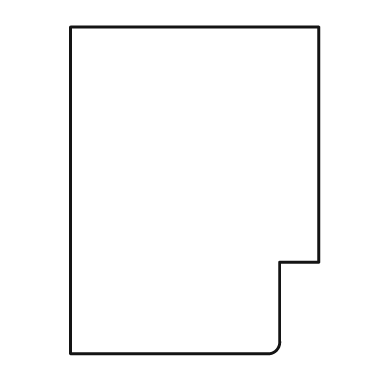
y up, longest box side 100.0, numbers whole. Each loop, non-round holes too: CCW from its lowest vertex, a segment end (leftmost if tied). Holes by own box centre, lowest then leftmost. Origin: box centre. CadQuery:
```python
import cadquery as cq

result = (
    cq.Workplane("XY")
    .moveTo(-38.0, -50.0)
    .lineTo(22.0, -50.0)
    .threePointArc((25.0, -49.0), (26.0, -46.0))
    .lineTo(26.0, -22.0)
    .lineTo(38.0, -22.0)
    .lineTo(38.0, 50.0)
    .lineTo(-38.0, 50.0)
    .close()
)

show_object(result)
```